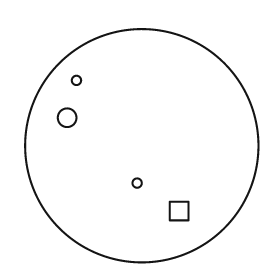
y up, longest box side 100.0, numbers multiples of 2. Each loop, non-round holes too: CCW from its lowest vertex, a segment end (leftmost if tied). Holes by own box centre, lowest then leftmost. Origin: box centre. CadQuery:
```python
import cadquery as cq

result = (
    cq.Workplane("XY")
    .moveTo(0.0, 0.0)
    .circle(50.0)
    .moveTo(12.0, -32.0)
    .lineTo(20.0, -32.0)
    .lineTo(20.0, -24.0)
    .lineTo(12.0, -24.0)
    .close()
    .moveTo(-2.0, -16.0)
    .circle(2.0)
    .moveTo(-32.0, 12.0)
    .circle(4.0)
    .moveTo(-28.0, 28.0)
    .circle(2.0)
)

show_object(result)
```